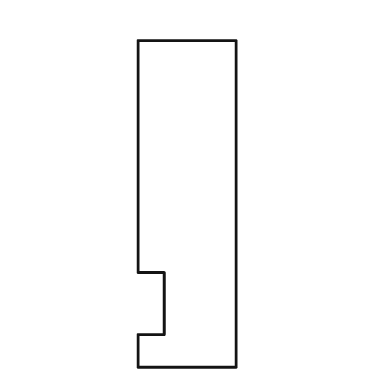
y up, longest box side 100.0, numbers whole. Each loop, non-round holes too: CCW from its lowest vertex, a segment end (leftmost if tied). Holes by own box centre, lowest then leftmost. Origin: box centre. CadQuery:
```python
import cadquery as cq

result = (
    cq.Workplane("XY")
    .moveTo(-15.0, -50.0)
    .lineTo(15.0, -50.0)
    .lineTo(15.0, 50.0)
    .lineTo(-15.0, 50.0)
    .lineTo(-15.0, -21.0)
    .lineTo(-7.0, -21.0)
    .lineTo(-7.0, -40.0)
    .lineTo(-15.0, -40.0)
    .close()
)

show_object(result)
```